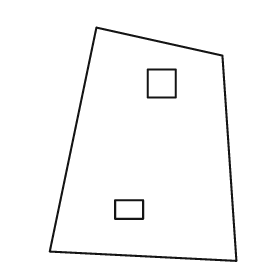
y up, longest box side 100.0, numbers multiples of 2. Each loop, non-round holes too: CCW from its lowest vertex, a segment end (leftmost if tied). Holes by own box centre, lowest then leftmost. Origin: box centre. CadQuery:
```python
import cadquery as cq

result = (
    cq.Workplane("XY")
    .moveTo(40.0, -50.0)
    .lineTo(34.0, 38.0)
    .lineTo(-20.0, 50.0)
    .lineTo(-40.0, -46.0)
    .close()
    .moveTo(-12.0, -32.0)
    .lineTo(0.0, -32.0)
    .lineTo(0.0, -24.0)
    .lineTo(-12.0, -24.0)
    .close()
    .moveTo(2.0, 20.0)
    .lineTo(14.0, 20.0)
    .lineTo(14.0, 32.0)
    .lineTo(2.0, 32.0)
    .close()
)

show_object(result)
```